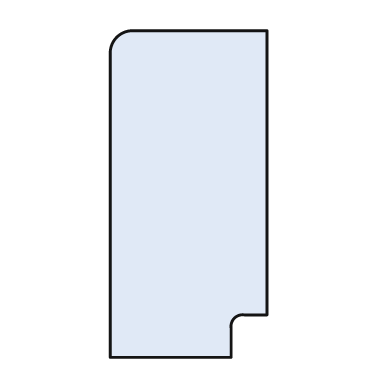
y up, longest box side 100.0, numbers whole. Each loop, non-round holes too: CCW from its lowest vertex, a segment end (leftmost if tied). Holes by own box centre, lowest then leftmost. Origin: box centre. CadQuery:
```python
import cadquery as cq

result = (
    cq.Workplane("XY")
    .moveTo(-24.0, -50.0)
    .lineTo(13.0, -50.0)
    .lineTo(13.0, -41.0)
    .threePointArc((14.0, -38.0), (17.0, -37.0))
    .lineTo(24.0, -37.0)
    .lineTo(24.0, 50.0)
    .lineTo(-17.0, 50.0)
    .threePointArc((-22.0, 48.0), (-24.0, 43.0))
    .close()
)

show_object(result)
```